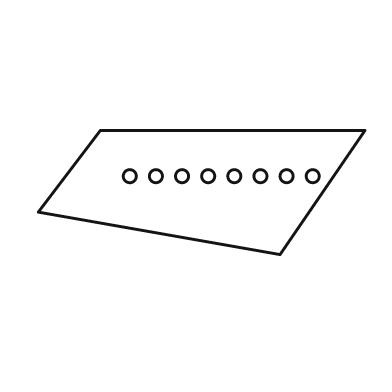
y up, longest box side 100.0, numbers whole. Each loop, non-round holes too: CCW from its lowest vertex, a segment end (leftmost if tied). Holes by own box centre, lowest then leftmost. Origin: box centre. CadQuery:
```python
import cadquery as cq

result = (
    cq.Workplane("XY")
    .moveTo(24.0, -19.0)
    .lineTo(50.0, 19.0)
    .lineTo(-31.0, 19.0)
    .lineTo(-50.0, -6.0)
    .close()
    .moveTo(-22.0, 5.0)
    .circle(2.0)
    .moveTo(-14.0, 5.0)
    .circle(2.0)
    .moveTo(-6.0, 5.0)
    .circle(2.0)
    .moveTo(2.0, 5.0)
    .circle(2.0)
    .moveTo(10.0, 5.0)
    .circle(2.0)
    .moveTo(18.0, 5.0)
    .circle(2.0)
    .moveTo(26.0, 5.0)
    .circle(2.0)
    .moveTo(34.0, 5.0)
    .circle(2.0)
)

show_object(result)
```